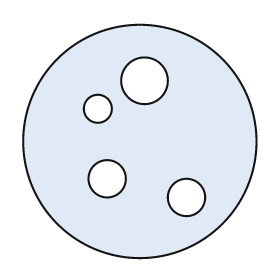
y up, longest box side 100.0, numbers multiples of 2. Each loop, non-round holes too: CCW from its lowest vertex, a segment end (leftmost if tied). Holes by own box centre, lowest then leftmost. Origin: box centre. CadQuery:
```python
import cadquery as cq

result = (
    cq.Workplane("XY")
    .moveTo(0.0, 0.0)
    .circle(50.0)
    .moveTo(20.0, -24.0)
    .circle(8.0)
    .moveTo(-14.0, -16.0)
    .circle(8.0)
    .moveTo(-18.0, 14.0)
    .circle(6.0)
    .moveTo(2.0, 26.0)
    .circle(10.0)
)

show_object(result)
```